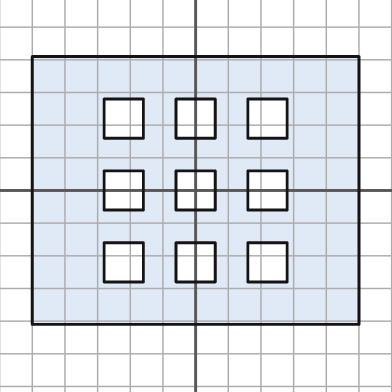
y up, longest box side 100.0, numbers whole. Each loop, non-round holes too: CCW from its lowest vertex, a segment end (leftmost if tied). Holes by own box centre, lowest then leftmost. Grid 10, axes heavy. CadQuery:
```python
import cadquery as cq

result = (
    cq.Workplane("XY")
    .moveTo(-50.0, -41.0)
    .lineTo(50.0, -41.0)
    .lineTo(50.0, 41.0)
    .lineTo(-50.0, 41.0)
    .close()
    .moveTo(-28.0, -28.0)
    .lineTo(-16.0, -28.0)
    .lineTo(-16.0, -16.0)
    .lineTo(-28.0, -16.0)
    .close()
    .moveTo(-6.0, -28.0)
    .lineTo(6.0, -28.0)
    .lineTo(6.0, -16.0)
    .lineTo(-6.0, -16.0)
    .close()
    .moveTo(16.0, -28.0)
    .lineTo(28.0, -28.0)
    .lineTo(28.0, -16.0)
    .lineTo(16.0, -16.0)
    .close()
    .moveTo(-28.0, -6.0)
    .lineTo(-16.0, -6.0)
    .lineTo(-16.0, 6.0)
    .lineTo(-28.0, 6.0)
    .close()
    .moveTo(-6.0, -6.0)
    .lineTo(6.0, -6.0)
    .lineTo(6.0, 6.0)
    .lineTo(-6.0, 6.0)
    .close()
    .moveTo(16.0, -6.0)
    .lineTo(28.0, -6.0)
    .lineTo(28.0, 6.0)
    .lineTo(16.0, 6.0)
    .close()
    .moveTo(-28.0, 16.0)
    .lineTo(-16.0, 16.0)
    .lineTo(-16.0, 28.0)
    .lineTo(-28.0, 28.0)
    .close()
    .moveTo(-6.0, 16.0)
    .lineTo(6.0, 16.0)
    .lineTo(6.0, 28.0)
    .lineTo(-6.0, 28.0)
    .close()
    .moveTo(16.0, 16.0)
    .lineTo(28.0, 16.0)
    .lineTo(28.0, 28.0)
    .lineTo(16.0, 28.0)
    .close()
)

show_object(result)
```